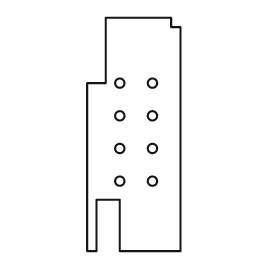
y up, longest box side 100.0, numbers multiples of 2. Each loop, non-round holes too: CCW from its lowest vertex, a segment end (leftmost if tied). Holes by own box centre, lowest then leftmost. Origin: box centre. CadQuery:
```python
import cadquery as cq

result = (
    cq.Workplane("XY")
    .moveTo(-20.0, -50.0)
    .lineTo(-16.0, -50.0)
    .lineTo(-16.0, -28.0)
    .lineTo(-6.0, -28.0)
    .lineTo(-6.0, -50.0)
    .lineTo(20.0, -50.0)
    .lineTo(20.0, 46.0)
    .lineTo(16.0, 46.0)
    .lineTo(16.0, 50.0)
    .lineTo(-12.0, 50.0)
    .lineTo(-12.0, 22.0)
    .lineTo(-20.0, 22.0)
    .close()
    .moveTo(-6.0, -20.0)
    .circle(2.0)
    .moveTo(8.0, -20.0)
    .circle(2.0)
    .moveTo(-6.0, -6.0)
    .circle(2.0)
    .moveTo(8.0, -6.0)
    .circle(2.0)
    .moveTo(-6.0, 8.0)
    .circle(2.0)
    .moveTo(8.0, 8.0)
    .circle(2.0)
    .moveTo(-6.0, 22.0)
    .circle(2.0)
    .moveTo(8.0, 22.0)
    .circle(2.0)
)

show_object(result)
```